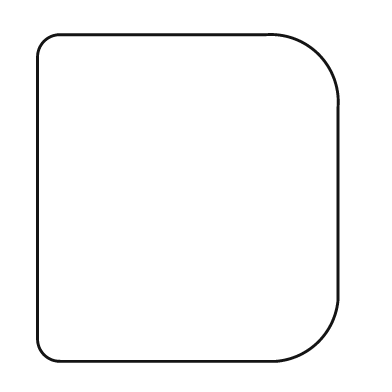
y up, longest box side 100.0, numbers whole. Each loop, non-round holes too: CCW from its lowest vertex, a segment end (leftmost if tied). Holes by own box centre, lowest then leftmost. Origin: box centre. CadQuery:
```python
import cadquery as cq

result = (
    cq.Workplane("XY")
    .moveTo(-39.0, -50.0)
    .lineTo(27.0, -50.0)
    .threePointArc((40.0, -44.0), (46.0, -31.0))
    .lineTo(46.0, 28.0)
    .threePointArc((40.0, 44.0), (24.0, 50.0))
    .lineTo(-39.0, 50.0)
    .threePointArc((-44.0, 48.0), (-46.0, 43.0))
    .lineTo(-46.0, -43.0)
    .threePointArc((-44.0, -48.0), (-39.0, -50.0))
    .close()
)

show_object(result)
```